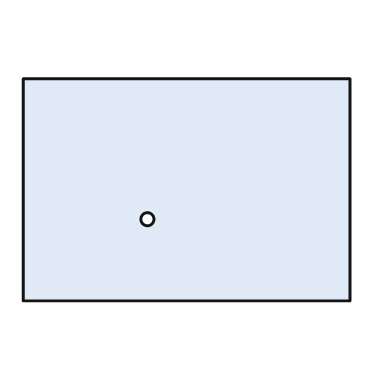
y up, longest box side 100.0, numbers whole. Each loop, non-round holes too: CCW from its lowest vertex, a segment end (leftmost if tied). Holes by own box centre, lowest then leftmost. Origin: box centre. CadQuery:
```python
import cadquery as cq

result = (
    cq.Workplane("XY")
    .moveTo(-50.0, -34.0)
    .lineTo(50.0, -34.0)
    .lineTo(50.0, 34.0)
    .lineTo(-50.0, 34.0)
    .close()
    .moveTo(-12.0, -9.0)
    .circle(2.0)
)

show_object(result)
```